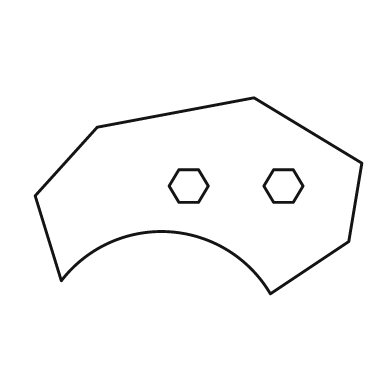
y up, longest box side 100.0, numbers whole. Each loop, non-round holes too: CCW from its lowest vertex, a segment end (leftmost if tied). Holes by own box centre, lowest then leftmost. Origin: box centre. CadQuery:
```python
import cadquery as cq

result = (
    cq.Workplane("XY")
    .moveTo(22.0, -30.0)
    .lineTo(46.0, -14.0)
    .lineTo(50.0, 10.0)
    .lineTo(17.0, 30.0)
    .lineTo(-31.0, 21.0)
    .lineTo(-50.0, 0.0)
    .lineTo(-42.0, -26.0)
    .threePointArc((-9.0, -11.0), (22.0, -30.0))
    .close()
    .moveTo(-6.0, -2.0)
    .lineTo(0.0, -2.0)
    .lineTo(3.0, 3.0)
    .lineTo(0.0, 8.0)
    .lineTo(-6.0, 8.0)
    .lineTo(-9.0, 3.0)
    .close()
    .moveTo(23.0, -2.0)
    .lineTo(29.0, -2.0)
    .lineTo(32.0, 3.0)
    .lineTo(29.0, 8.0)
    .lineTo(23.0, 8.0)
    .lineTo(20.0, 3.0)
    .close()
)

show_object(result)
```